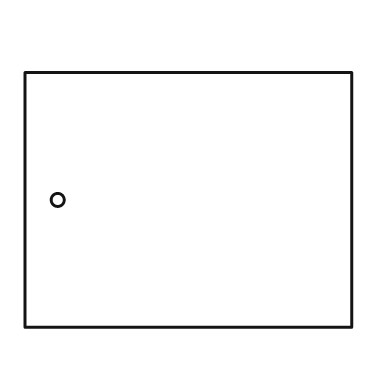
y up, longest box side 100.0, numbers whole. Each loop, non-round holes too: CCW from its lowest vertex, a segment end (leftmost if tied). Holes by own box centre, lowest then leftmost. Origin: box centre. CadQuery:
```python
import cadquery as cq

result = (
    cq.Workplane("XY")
    .moveTo(-50.0, -39.0)
    .lineTo(50.0, -39.0)
    .lineTo(50.0, 39.0)
    .lineTo(-50.0, 39.0)
    .close()
    .moveTo(-40.0, 0.0)
    .circle(2.0)
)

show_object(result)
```